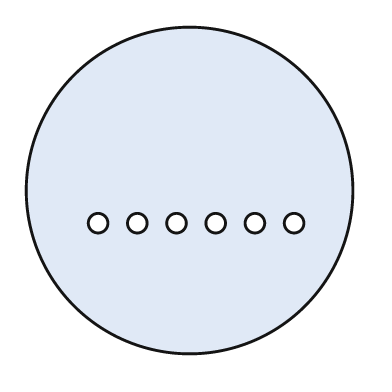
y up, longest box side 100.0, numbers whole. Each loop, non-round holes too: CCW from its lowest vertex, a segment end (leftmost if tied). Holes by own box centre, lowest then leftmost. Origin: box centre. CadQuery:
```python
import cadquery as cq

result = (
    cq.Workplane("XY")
    .moveTo(0.0, 0.0)
    .circle(50.0)
    .moveTo(-28.0, -10.0)
    .circle(3.0)
    .moveTo(-16.0, -10.0)
    .circle(3.0)
    .moveTo(-4.0, -10.0)
    .circle(3.0)
    .moveTo(8.0, -10.0)
    .circle(3.0)
    .moveTo(20.0, -10.0)
    .circle(3.0)
    .moveTo(32.0, -10.0)
    .circle(3.0)
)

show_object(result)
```